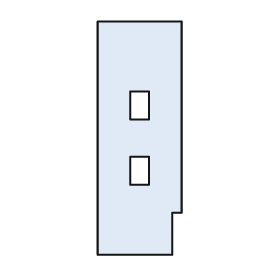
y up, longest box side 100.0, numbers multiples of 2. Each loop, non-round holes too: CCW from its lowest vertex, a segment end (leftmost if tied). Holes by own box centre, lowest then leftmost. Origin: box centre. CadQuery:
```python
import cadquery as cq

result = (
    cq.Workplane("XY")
    .moveTo(-18.0, -50.0)
    .lineTo(14.0, -50.0)
    .lineTo(14.0, -32.0)
    .lineTo(18.0, -32.0)
    .lineTo(18.0, 50.0)
    .lineTo(-18.0, 50.0)
    .close()
    .moveTo(-4.0, -20.0)
    .lineTo(4.0, -20.0)
    .lineTo(4.0, -8.0)
    .lineTo(-4.0, -8.0)
    .close()
    .moveTo(-4.0, 8.0)
    .lineTo(4.0, 8.0)
    .lineTo(4.0, 20.0)
    .lineTo(-4.0, 20.0)
    .close()
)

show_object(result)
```